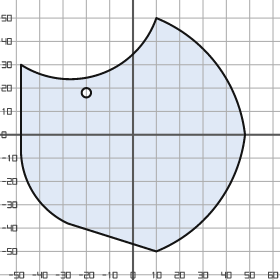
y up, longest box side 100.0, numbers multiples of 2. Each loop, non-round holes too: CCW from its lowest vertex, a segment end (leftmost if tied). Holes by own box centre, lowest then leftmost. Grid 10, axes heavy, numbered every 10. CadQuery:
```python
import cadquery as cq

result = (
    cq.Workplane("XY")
    .moveTo(10.0, -50.0)
    .threePointArc((36.0, -30.0), (48.0, 0.0))
    .threePointArc((36.0, 30.0), (10.0, 50.0))
    .threePointArc((-14.0, 26.0), (-48.0, 30.0))
    .lineTo(-48.0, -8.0)
    .threePointArc((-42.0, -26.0), (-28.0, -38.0))
    .close()
    .moveTo(-20.0, 18.0)
    .circle(2.0)
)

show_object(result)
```